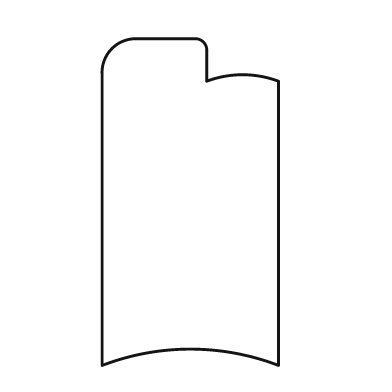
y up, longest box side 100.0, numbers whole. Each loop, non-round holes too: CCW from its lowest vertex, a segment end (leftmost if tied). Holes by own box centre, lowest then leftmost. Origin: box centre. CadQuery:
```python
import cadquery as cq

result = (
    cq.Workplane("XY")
    .moveTo(-27.0, -50.0)
    .threePointArc((0.0, -45.0), (27.0, -50.0))
    .lineTo(27.0, 37.0)
    .threePointArc((16.0, 39.0), (5.0, 37.0))
    .lineTo(5.0, 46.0)
    .threePointArc((4.0, 49.0), (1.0, 50.0))
    .lineTo(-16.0, 50.0)
    .threePointArc((-24.0, 47.0), (-27.0, 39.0))
    .close()
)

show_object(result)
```